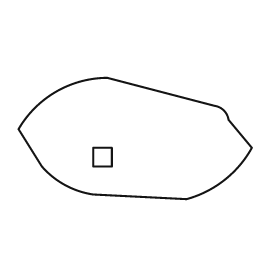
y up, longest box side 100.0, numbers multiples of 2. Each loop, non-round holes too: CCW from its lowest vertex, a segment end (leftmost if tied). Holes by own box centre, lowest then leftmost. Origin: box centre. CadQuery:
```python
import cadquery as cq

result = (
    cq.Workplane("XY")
    .moveTo(22.0, -26.0)
    .threePointArc((38.0, -18.0), (50.0, -4.0))
    .lineTo(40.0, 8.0)
    .threePointArc((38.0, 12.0), (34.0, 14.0))
    .lineTo(-12.0, 26.0)
    .threePointArc((-34.0, 20.0), (-50.0, 4.0))
    .lineTo(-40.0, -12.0)
    .threePointArc((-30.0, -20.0), (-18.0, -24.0))
    .close()
    .moveTo(-18.0, -12.0)
    .lineTo(-10.0, -12.0)
    .lineTo(-10.0, -4.0)
    .lineTo(-18.0, -4.0)
    .close()
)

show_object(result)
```